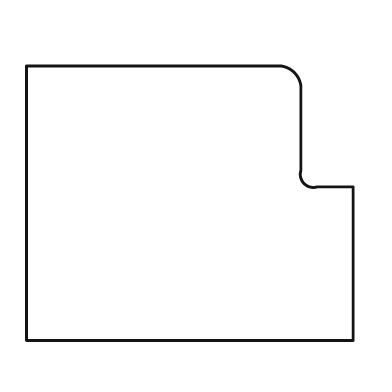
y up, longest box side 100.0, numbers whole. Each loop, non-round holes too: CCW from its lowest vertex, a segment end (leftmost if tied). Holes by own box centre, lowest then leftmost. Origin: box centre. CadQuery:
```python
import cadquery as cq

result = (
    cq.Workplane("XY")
    .moveTo(-50.0, -42.0)
    .lineTo(50.0, -42.0)
    .lineTo(50.0, 5.0)
    .lineTo(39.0, 5.0)
    .threePointArc((35.0, 6.0), (34.0, 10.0))
    .lineTo(34.0, 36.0)
    .threePointArc((32.0, 40.0), (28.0, 42.0))
    .lineTo(-50.0, 42.0)
    .close()
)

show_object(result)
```